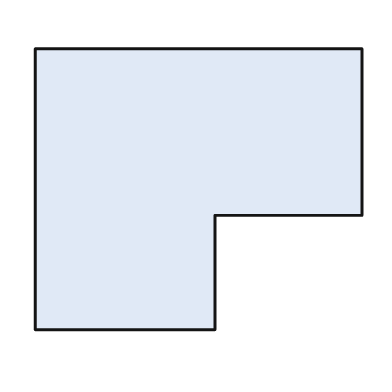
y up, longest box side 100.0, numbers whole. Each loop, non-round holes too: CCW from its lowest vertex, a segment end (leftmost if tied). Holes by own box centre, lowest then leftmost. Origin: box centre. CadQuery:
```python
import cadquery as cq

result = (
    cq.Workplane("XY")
    .moveTo(-50.0, -43.0)
    .lineTo(5.0, -43.0)
    .lineTo(5.0, -8.0)
    .lineTo(50.0, -8.0)
    .lineTo(50.0, 43.0)
    .lineTo(-50.0, 43.0)
    .close()
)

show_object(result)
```